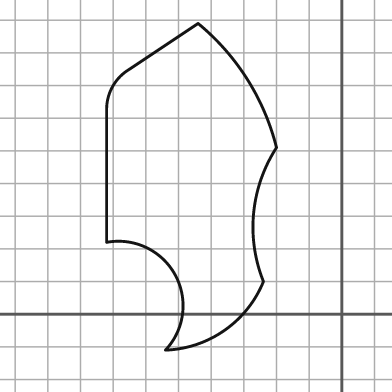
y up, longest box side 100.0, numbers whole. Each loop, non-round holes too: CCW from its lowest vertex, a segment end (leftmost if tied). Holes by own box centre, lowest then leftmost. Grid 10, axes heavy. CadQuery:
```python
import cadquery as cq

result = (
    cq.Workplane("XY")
    .moveTo(-54.0, -11.0)
    .threePointArc((-36.0, -5.0), (-24.0, 10.0))
    .threePointArc((-27.0, 31.0), (-20.0, 51.0))
    .threePointArc((-29.0, 72.0), (-44.0, 89.0))
    .lineTo(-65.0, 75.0)
    .threePointArc((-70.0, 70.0), (-72.0, 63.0))
    .lineTo(-72.0, 22.0)
    .threePointArc((-51.0, 12.0), (-54.0, -11.0))
    .close()
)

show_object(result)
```